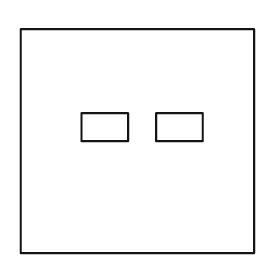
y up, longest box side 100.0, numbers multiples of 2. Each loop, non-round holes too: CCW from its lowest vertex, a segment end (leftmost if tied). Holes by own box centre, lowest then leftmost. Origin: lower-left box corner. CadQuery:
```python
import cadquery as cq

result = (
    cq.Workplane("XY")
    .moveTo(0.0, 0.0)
    .lineTo(100.0, 0.0)
    .lineTo(100.0, 96.0)
    .lineTo(0.0, 96.0)
    .close()
    .moveTo(26.0, 48.0)
    .lineTo(46.0, 48.0)
    .lineTo(46.0, 60.0)
    .lineTo(26.0, 60.0)
    .close()
    .moveTo(58.0, 48.0)
    .lineTo(78.0, 48.0)
    .lineTo(78.0, 60.0)
    .lineTo(58.0, 60.0)
    .close()
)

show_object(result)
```